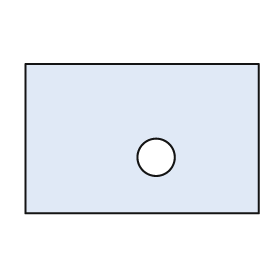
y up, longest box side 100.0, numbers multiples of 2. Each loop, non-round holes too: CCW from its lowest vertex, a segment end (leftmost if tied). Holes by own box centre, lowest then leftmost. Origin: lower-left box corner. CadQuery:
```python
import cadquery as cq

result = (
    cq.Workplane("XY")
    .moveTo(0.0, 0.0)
    .lineTo(100.0, 0.0)
    .lineTo(100.0, 64.0)
    .lineTo(0.0, 64.0)
    .close()
    .moveTo(56.0, 24.0)
    .circle(8.0)
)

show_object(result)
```